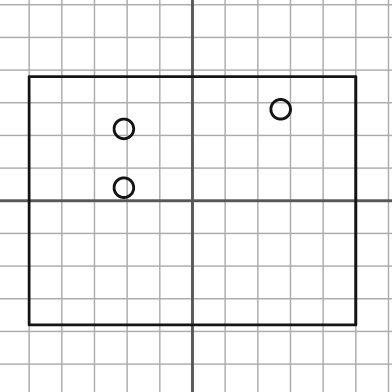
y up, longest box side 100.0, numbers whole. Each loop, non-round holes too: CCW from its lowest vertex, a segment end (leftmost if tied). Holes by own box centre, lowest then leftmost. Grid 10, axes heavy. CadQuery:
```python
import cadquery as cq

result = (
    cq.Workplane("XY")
    .moveTo(-50.0, -38.0)
    .lineTo(50.0, -38.0)
    .lineTo(50.0, 38.0)
    .lineTo(-50.0, 38.0)
    .close()
    .moveTo(-21.0, 4.0)
    .circle(3.0)
    .moveTo(-21.0, 22.0)
    .circle(3.0)
    .moveTo(27.0, 28.0)
    .circle(3.0)
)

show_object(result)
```